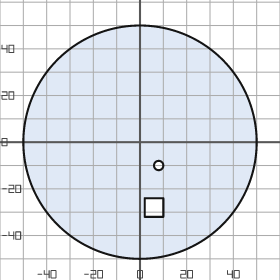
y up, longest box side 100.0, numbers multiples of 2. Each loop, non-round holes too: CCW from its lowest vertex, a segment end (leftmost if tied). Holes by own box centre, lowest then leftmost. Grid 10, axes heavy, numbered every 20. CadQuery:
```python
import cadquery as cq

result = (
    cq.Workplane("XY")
    .moveTo(0.0, 0.0)
    .circle(50.0)
    .moveTo(2.0, -32.0)
    .lineTo(10.0, -32.0)
    .lineTo(10.0, -24.0)
    .lineTo(2.0, -24.0)
    .close()
    .moveTo(8.0, -10.0)
    .circle(2.0)
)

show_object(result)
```